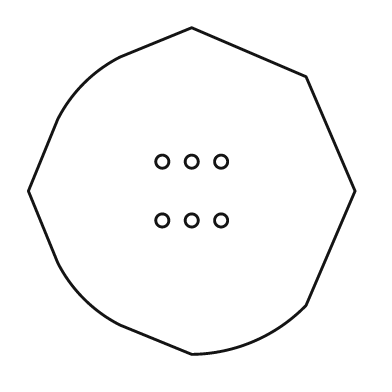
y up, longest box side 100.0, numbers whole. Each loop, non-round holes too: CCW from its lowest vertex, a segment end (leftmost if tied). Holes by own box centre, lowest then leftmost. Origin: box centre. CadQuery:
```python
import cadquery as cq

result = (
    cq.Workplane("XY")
    .moveTo(0.0, -50.0)
    .threePointArc((19.0, -46.0), (35.0, -35.0))
    .lineTo(50.0, 0.0)
    .lineTo(35.0, 35.0)
    .lineTo(0.0, 50.0)
    .lineTo(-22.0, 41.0)
    .threePointArc((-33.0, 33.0), (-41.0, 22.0))
    .lineTo(-50.0, 0.0)
    .lineTo(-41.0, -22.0)
    .threePointArc((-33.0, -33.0), (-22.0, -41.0))
    .close()
    .moveTo(-9.0, -9.0)
    .circle(2.0)
    .moveTo(0.0, -9.0)
    .circle(2.0)
    .moveTo(9.0, -9.0)
    .circle(2.0)
    .moveTo(-9.0, 9.0)
    .circle(2.0)
    .moveTo(0.0, 9.0)
    .circle(2.0)
    .moveTo(9.0, 9.0)
    .circle(2.0)
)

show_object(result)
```